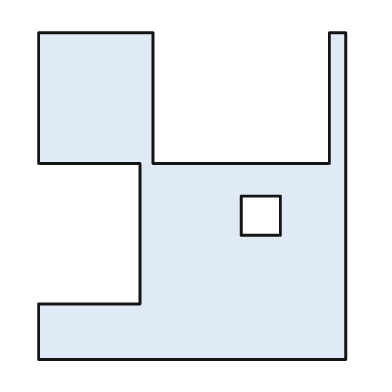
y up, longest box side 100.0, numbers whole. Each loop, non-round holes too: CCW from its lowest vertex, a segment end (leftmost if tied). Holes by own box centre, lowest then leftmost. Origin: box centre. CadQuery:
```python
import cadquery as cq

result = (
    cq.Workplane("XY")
    .moveTo(-47.0, -50.0)
    .lineTo(47.0, -50.0)
    .lineTo(47.0, 50.0)
    .lineTo(42.0, 50.0)
    .lineTo(42.0, 10.0)
    .lineTo(-12.0, 10.0)
    .lineTo(-12.0, 50.0)
    .lineTo(-47.0, 50.0)
    .lineTo(-47.0, 10.0)
    .lineTo(-16.0, 10.0)
    .lineTo(-16.0, -33.0)
    .lineTo(-47.0, -33.0)
    .close()
    .moveTo(15.0, -12.0)
    .lineTo(27.0, -12.0)
    .lineTo(27.0, 0.0)
    .lineTo(15.0, 0.0)
    .close()
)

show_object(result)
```